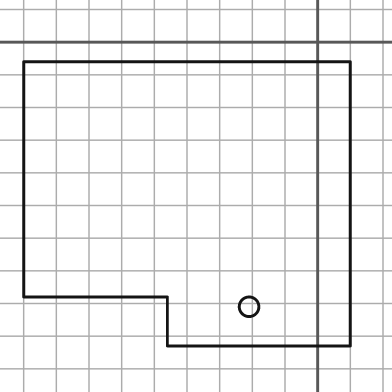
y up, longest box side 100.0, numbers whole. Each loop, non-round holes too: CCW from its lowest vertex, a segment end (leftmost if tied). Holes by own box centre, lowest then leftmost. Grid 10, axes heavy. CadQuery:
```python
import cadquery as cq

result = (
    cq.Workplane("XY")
    .moveTo(-46.0, -93.0)
    .lineTo(10.0, -93.0)
    .lineTo(10.0, -6.0)
    .lineTo(-90.0, -6.0)
    .lineTo(-90.0, -78.0)
    .lineTo(-46.0, -78.0)
    .close()
    .moveTo(-21.0, -81.0)
    .circle(3.0)
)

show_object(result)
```